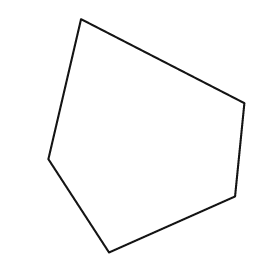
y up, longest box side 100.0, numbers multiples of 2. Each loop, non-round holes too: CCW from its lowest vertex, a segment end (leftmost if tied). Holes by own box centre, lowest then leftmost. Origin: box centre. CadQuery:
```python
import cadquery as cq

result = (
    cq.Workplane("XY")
    .moveTo(-16.0, -50.0)
    .lineTo(38.0, -26.0)
    .lineTo(42.0, 14.0)
    .lineTo(-28.0, 50.0)
    .lineTo(-42.0, -10.0)
    .close()
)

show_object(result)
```